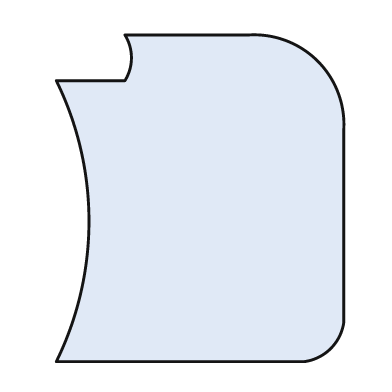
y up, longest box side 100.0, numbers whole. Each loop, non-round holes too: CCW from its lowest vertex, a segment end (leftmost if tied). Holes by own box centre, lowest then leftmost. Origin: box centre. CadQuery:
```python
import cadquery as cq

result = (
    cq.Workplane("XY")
    .moveTo(-44.0, -50.0)
    .lineTo(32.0, -50.0)
    .threePointArc((40.0, -46.0), (44.0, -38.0))
    .lineTo(44.0, 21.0)
    .threePointArc((36.0, 42.0), (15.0, 50.0))
    .lineTo(-23.0, 50.0)
    .threePointArc((-21.0, 43.0), (-23.0, 36.0))
    .lineTo(-44.0, 36.0)
    .threePointArc((-34.0, -7.0), (-44.0, -50.0))
    .close()
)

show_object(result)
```